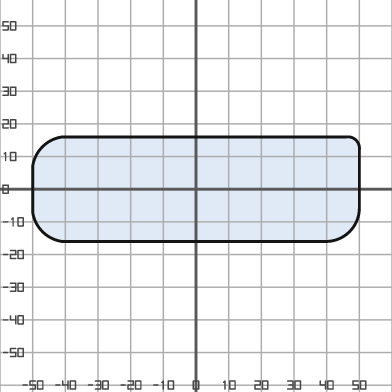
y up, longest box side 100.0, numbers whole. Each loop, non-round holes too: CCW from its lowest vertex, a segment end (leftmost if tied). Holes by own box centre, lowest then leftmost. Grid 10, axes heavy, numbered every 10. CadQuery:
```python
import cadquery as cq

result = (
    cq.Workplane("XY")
    .moveTo(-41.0, -16.0)
    .lineTo(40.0, -16.0)
    .threePointArc((47.0, -13.0), (50.0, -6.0))
    .lineTo(50.0, 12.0)
    .threePointArc((49.0, 15.0), (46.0, 16.0))
    .lineTo(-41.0, 16.0)
    .threePointArc((-47.0, 13.0), (-50.0, 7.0))
    .lineTo(-50.0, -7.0)
    .threePointArc((-47.0, -13.0), (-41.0, -16.0))
    .close()
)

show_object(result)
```